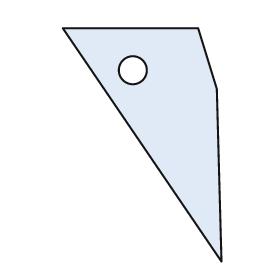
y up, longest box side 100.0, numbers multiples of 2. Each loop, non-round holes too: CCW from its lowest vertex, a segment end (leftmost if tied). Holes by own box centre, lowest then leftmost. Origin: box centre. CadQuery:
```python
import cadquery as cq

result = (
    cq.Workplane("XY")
    .moveTo(34.0, -50.0)
    .lineTo(32.0, 24.0)
    .lineTo(24.0, 50.0)
    .lineTo(-34.0, 50.0)
    .close()
    .moveTo(-4.0, 32.0)
    .circle(6.0)
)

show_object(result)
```